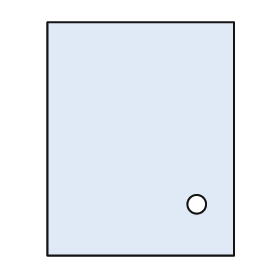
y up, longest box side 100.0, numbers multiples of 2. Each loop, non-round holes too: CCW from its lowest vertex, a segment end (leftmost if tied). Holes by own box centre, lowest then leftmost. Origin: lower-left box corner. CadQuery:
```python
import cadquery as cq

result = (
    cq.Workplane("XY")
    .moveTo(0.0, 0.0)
    .lineTo(80.0, 0.0)
    .lineTo(80.0, 100.0)
    .lineTo(0.0, 100.0)
    .close()
    .moveTo(64.0, 22.0)
    .circle(4.0)
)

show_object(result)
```